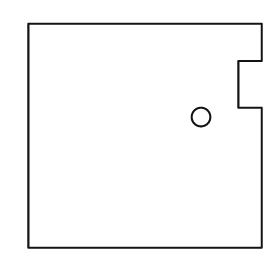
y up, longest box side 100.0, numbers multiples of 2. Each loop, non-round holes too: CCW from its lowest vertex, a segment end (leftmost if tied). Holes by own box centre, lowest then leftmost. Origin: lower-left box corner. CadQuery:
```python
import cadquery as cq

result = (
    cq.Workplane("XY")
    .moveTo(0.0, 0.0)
    .lineTo(100.0, 0.0)
    .lineTo(100.0, 60.0)
    .lineTo(90.0, 60.0)
    .lineTo(90.0, 80.0)
    .lineTo(100.0, 80.0)
    .lineTo(100.0, 96.0)
    .lineTo(0.0, 96.0)
    .close()
    .moveTo(74.0, 56.0)
    .circle(4.0)
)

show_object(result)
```